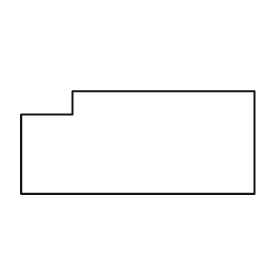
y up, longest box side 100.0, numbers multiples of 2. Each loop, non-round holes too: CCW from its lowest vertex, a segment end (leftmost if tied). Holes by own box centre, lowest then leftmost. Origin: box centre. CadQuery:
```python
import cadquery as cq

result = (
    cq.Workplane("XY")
    .moveTo(-50.0, -22.0)
    .lineTo(50.0, -22.0)
    .lineTo(50.0, 22.0)
    .lineTo(-28.0, 22.0)
    .lineTo(-28.0, 12.0)
    .lineTo(-50.0, 12.0)
    .close()
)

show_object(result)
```